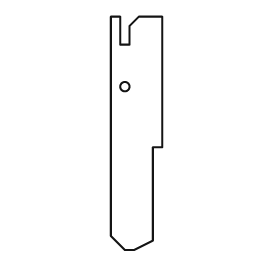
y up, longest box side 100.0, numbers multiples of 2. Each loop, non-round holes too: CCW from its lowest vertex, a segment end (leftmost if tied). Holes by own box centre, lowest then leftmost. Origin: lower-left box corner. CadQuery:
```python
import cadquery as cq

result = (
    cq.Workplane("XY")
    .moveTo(6.0, 0.0)
    .lineTo(10.0, 0.0)
    .lineTo(18.0, 4.0)
    .lineTo(18.0, 44.0)
    .lineTo(22.0, 44.0)
    .lineTo(22.0, 100.0)
    .lineTo(12.0, 100.0)
    .lineTo(8.0, 96.0)
    .lineTo(8.0, 88.0)
    .lineTo(4.0, 88.0)
    .lineTo(4.0, 100.0)
    .lineTo(0.0, 100.0)
    .lineTo(0.0, 6.0)
    .close()
    .moveTo(6.0, 70.0)
    .circle(2.0)
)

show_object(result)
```